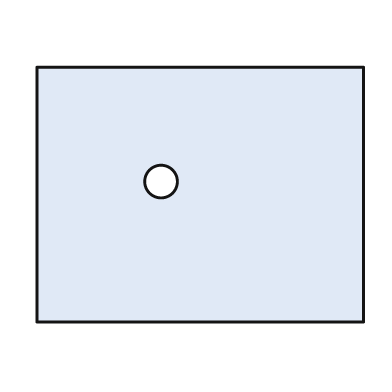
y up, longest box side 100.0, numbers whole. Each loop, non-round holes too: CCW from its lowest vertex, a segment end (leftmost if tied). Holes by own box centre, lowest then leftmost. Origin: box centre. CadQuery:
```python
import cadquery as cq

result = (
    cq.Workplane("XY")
    .moveTo(-50.0, -39.0)
    .lineTo(50.0, -39.0)
    .lineTo(50.0, 39.0)
    .lineTo(-50.0, 39.0)
    .close()
    .moveTo(-12.0, 4.0)
    .circle(5.0)
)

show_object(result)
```